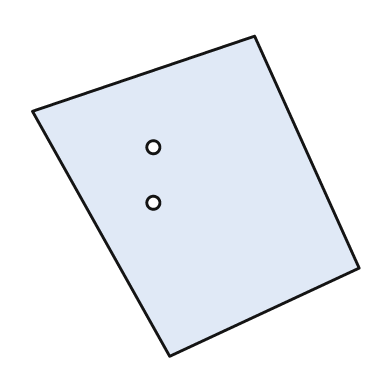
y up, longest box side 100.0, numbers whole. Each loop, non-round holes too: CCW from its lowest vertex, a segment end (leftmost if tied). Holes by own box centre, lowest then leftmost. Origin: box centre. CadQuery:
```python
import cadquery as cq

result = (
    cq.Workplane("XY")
    .moveTo(-8.0, -49.0)
    .lineTo(50.0, -22.0)
    .lineTo(18.0, 49.0)
    .lineTo(-50.0, 26.0)
    .close()
    .moveTo(-13.0, -2.0)
    .circle(2.0)
    .moveTo(-13.0, 15.0)
    .circle(2.0)
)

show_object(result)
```